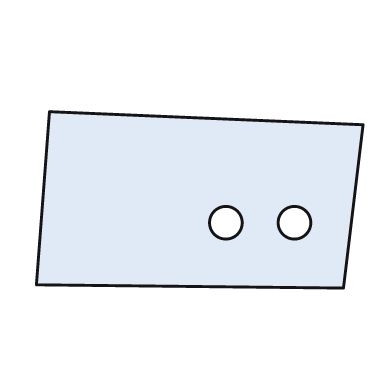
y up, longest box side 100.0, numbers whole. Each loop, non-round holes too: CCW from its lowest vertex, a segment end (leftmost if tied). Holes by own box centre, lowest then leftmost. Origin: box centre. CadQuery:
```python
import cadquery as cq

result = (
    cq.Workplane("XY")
    .moveTo(44.0, -27.0)
    .lineTo(50.0, 23.0)
    .lineTo(-46.0, 27.0)
    .lineTo(-50.0, -26.0)
    .close()
    .moveTo(8.0, -7.0)
    .circle(5.0)
    .moveTo(29.0, -7.0)
    .circle(5.0)
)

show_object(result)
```